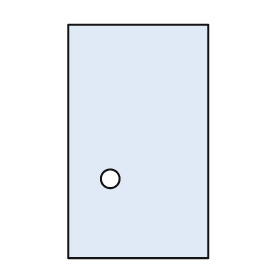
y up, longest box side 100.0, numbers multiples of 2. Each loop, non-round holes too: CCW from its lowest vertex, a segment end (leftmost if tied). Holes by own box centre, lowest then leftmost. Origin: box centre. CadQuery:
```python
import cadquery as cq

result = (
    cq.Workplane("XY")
    .moveTo(-30.0, -50.0)
    .lineTo(30.0, -50.0)
    .lineTo(30.0, 50.0)
    .lineTo(-30.0, 50.0)
    .close()
    .moveTo(-12.0, -16.0)
    .circle(4.0)
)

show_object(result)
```